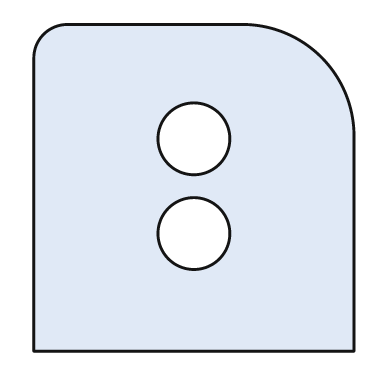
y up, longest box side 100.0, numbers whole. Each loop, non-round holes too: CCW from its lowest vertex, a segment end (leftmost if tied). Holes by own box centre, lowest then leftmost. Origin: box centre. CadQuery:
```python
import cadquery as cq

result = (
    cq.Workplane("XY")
    .moveTo(-49.0, -50.0)
    .lineTo(49.0, -50.0)
    .lineTo(49.0, 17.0)
    .threePointArc((39.0, 40.0), (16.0, 50.0))
    .lineTo(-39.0, 50.0)
    .threePointArc((-46.0, 47.0), (-49.0, 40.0))
    .close()
    .moveTo(0.0, -14.0)
    .circle(11.0)
    .moveTo(0.0, 15.0)
    .circle(11.0)
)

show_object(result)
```